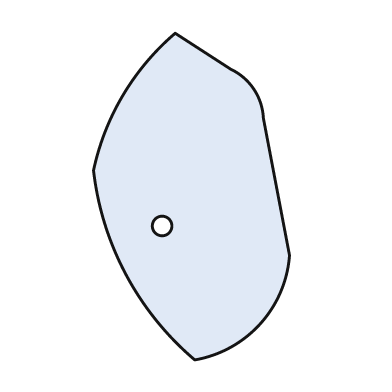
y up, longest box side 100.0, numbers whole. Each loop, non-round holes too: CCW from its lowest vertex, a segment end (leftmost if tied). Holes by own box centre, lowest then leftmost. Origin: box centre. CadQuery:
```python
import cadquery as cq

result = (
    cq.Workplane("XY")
    .moveTo(1.0, -50.0)
    .threePointArc((21.0, -39.0), (30.0, -18.0))
    .lineTo(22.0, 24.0)
    .threePointArc((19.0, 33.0), (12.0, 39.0))
    .lineTo(-5.0, 50.0)
    .threePointArc((-21.0, 31.0), (-30.0, 8.0))
    .threePointArc((-20.0, -24.0), (1.0, -50.0))
    .close()
    .moveTo(-9.0, -9.0)
    .circle(3.0)
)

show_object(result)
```